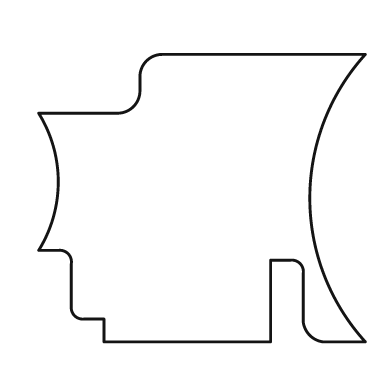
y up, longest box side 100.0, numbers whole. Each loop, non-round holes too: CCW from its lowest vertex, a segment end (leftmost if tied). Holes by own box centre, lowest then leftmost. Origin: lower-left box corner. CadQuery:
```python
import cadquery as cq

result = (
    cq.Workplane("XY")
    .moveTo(20.0, 0.0)
    .lineTo(71.0, 0.0)
    .lineTo(71.0, 25.0)
    .lineTo(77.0, 25.0)
    .threePointArc((80.0, 24.0), (81.0, 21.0))
    .lineTo(81.0, 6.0)
    .threePointArc((83.0, 2.0), (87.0, 0.0))
    .lineTo(100.0, 0.0)
    .threePointArc((83.0, 44.0), (100.0, 88.0))
    .lineTo(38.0, 88.0)
    .threePointArc((33.0, 86.0), (31.0, 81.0))
    .lineTo(31.0, 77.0)
    .threePointArc((29.0, 72.0), (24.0, 70.0))
    .lineTo(0.0, 70.0)
    .threePointArc((6.0, 49.0), (0.0, 28.0))
    .lineTo(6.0, 28.0)
    .threePointArc((9.0, 27.0), (10.0, 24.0))
    .lineTo(10.0, 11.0)
    .threePointArc((11.0, 8.0), (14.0, 7.0))
    .lineTo(20.0, 7.0)
    .close()
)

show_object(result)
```